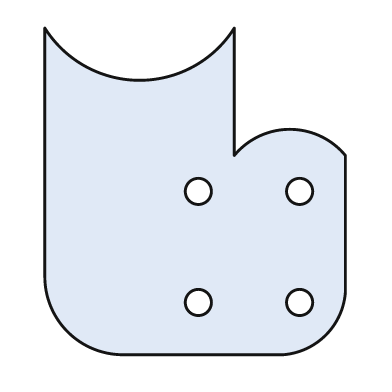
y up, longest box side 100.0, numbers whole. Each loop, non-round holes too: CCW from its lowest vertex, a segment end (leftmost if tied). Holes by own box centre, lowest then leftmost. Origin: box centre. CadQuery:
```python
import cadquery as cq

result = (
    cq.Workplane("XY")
    .moveTo(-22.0, -50.0)
    .lineTo(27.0, -50.0)
    .threePointArc((40.0, -44.0), (46.0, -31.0))
    .lineTo(46.0, 11.0)
    .threePointArc((29.0, 19.0), (12.0, 11.0))
    .lineTo(12.0, 50.0)
    .threePointArc((-17.0, 34.0), (-46.0, 50.0))
    .lineTo(-46.0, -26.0)
    .threePointArc((-39.0, -43.0), (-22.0, -50.0))
    .close()
    .moveTo(1.0, -34.0)
    .circle(4.0)
    .moveTo(32.0, -34.0)
    .circle(4.0)
    .moveTo(1.0, 0.0)
    .circle(4.0)
    .moveTo(32.0, 0.0)
    .circle(4.0)
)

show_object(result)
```